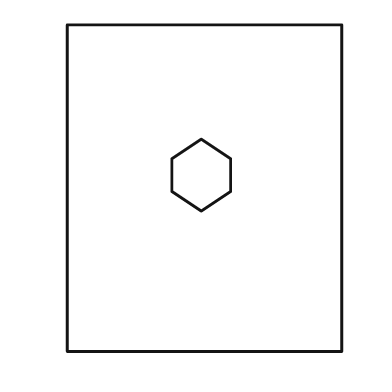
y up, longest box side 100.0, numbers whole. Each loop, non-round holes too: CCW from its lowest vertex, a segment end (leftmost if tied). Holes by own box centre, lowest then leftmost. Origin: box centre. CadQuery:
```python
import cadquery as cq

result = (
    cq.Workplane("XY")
    .moveTo(-42.0, -50.0)
    .lineTo(42.0, -50.0)
    .lineTo(42.0, 50.0)
    .lineTo(-42.0, 50.0)
    .close()
    .moveTo(-1.0, -7.0)
    .lineTo(8.0, -1.0)
    .lineTo(8.0, 9.0)
    .lineTo(-1.0, 15.0)
    .lineTo(-10.0, 9.0)
    .lineTo(-10.0, -1.0)
    .close()
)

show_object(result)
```